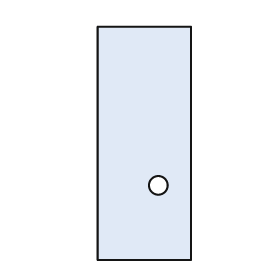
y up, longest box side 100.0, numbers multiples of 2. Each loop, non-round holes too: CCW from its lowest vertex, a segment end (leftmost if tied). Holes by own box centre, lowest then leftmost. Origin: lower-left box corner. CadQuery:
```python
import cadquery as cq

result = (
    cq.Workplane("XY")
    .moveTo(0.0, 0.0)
    .lineTo(40.0, 0.0)
    .lineTo(40.0, 100.0)
    .lineTo(0.0, 100.0)
    .close()
    .moveTo(26.0, 32.0)
    .circle(4.0)
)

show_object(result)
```